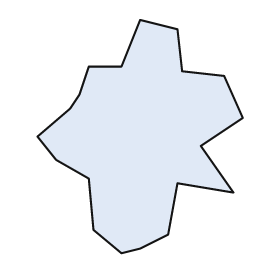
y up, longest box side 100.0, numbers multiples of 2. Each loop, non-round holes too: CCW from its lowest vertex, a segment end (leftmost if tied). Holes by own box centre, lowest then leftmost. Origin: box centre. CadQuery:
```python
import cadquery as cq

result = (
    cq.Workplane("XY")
    .moveTo(-8.0, -50.0)
    .lineTo(0.0, -48.0)
    .lineTo(12.0, -42.0)
    .lineTo(16.0, -20.0)
    .lineTo(40.0, -24.0)
    .lineTo(26.0, -4.0)
    .lineTo(44.0, 8.0)
    .lineTo(36.0, 26.0)
    .lineTo(18.0, 28.0)
    .lineTo(16.0, 46.0)
    .lineTo(0.0, 50.0)
    .lineTo(-8.0, 30.0)
    .lineTo(-22.0, 30.0)
    .lineTo(-26.0, 18.0)
    .lineTo(-30.0, 12.0)
    .lineTo(-44.0, 0.0)
    .lineTo(-36.0, -10.0)
    .lineTo(-22.0, -18.0)
    .lineTo(-20.0, -40.0)
    .close()
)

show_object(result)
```